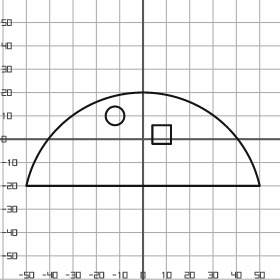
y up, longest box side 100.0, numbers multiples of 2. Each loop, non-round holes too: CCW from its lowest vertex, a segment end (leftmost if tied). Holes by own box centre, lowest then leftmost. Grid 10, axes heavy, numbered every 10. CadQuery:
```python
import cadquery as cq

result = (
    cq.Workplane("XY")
    .moveTo(-50.0, -20.0)
    .lineTo(50.0, -20.0)
    .threePointArc((0.0, 20.0), (-50.0, -20.0))
    .close()
    .moveTo(4.0, -2.0)
    .lineTo(12.0, -2.0)
    .lineTo(12.0, 6.0)
    .lineTo(4.0, 6.0)
    .close()
    .moveTo(-12.0, 10.0)
    .circle(4.0)
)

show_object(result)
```